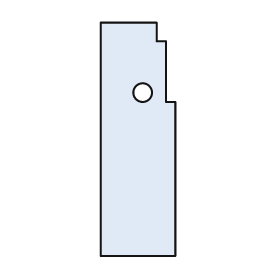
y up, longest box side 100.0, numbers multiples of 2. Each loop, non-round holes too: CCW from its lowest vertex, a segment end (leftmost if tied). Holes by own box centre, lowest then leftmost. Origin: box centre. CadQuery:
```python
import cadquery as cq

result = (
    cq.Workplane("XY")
    .moveTo(-16.0, -50.0)
    .lineTo(16.0, -50.0)
    .lineTo(16.0, 16.0)
    .lineTo(12.0, 16.0)
    .lineTo(12.0, 42.0)
    .lineTo(8.0, 42.0)
    .lineTo(8.0, 50.0)
    .lineTo(-16.0, 50.0)
    .close()
    .moveTo(2.0, 20.0)
    .circle(4.0)
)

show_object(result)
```